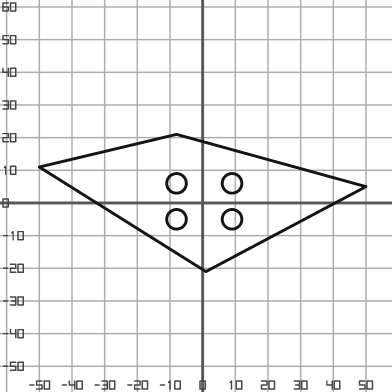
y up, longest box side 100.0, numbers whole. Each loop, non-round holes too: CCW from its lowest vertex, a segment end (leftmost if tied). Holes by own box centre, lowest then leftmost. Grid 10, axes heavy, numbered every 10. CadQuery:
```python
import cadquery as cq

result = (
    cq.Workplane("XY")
    .moveTo(1.0, -21.0)
    .lineTo(50.0, 5.0)
    .lineTo(-8.0, 21.0)
    .lineTo(-50.0, 11.0)
    .close()
    .moveTo(-8.0, -5.0)
    .circle(3.0)
    .moveTo(9.0, -5.0)
    .circle(3.0)
    .moveTo(-8.0, 6.0)
    .circle(3.0)
    .moveTo(9.0, 6.0)
    .circle(3.0)
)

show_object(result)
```